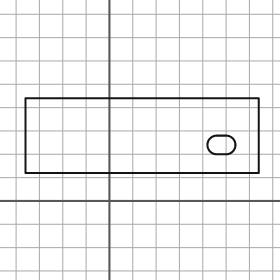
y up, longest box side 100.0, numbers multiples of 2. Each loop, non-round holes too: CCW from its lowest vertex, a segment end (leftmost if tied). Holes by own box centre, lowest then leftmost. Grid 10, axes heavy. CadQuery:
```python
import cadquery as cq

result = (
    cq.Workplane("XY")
    .moveTo(-36.0, 12.0)
    .lineTo(64.0, 12.0)
    .lineTo(64.0, 44.0)
    .lineTo(-36.0, 44.0)
    .close()
    .moveTo(46.0, 20.0)
    .lineTo(50.0, 20.0)
    .threePointArc((54.0, 24.0), (50.0, 28.0))
    .lineTo(46.0, 28.0)
    .threePointArc((42.0, 24.0), (46.0, 20.0))
    .close()
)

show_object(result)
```